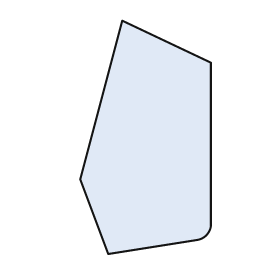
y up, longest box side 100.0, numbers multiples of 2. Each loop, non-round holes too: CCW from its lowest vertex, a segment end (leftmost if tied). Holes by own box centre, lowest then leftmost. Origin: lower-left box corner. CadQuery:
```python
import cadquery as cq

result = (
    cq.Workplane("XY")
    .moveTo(12.0, 0.0)
    .lineTo(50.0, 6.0)
    .threePointArc((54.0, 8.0), (56.0, 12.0))
    .lineTo(56.0, 82.0)
    .lineTo(18.0, 100.0)
    .lineTo(0.0, 32.0)
    .close()
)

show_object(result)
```